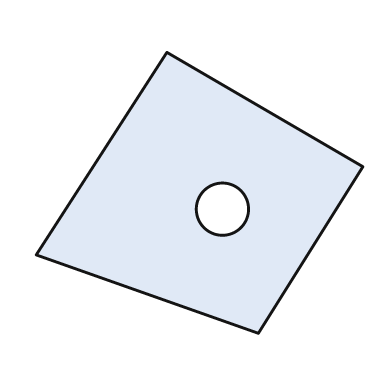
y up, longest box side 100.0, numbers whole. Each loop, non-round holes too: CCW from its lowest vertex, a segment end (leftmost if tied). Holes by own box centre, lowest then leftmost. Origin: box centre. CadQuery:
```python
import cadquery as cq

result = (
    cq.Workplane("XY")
    .moveTo(18.0, -43.0)
    .lineTo(50.0, 8.0)
    .lineTo(-10.0, 43.0)
    .lineTo(-50.0, -19.0)
    .close()
    .moveTo(7.0, -5.0)
    .circle(8.0)
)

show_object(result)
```